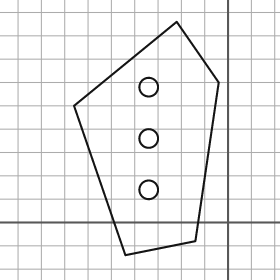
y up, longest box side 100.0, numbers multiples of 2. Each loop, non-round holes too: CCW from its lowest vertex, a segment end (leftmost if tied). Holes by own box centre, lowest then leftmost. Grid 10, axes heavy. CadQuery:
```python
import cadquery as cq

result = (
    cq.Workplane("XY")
    .moveTo(-44.0, -14.0)
    .lineTo(-14.0, -8.0)
    .lineTo(-4.0, 60.0)
    .lineTo(-22.0, 86.0)
    .lineTo(-66.0, 50.0)
    .close()
    .moveTo(-34.0, 14.0)
    .circle(4.0)
    .moveTo(-34.0, 36.0)
    .circle(4.0)
    .moveTo(-34.0, 58.0)
    .circle(4.0)
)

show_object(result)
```